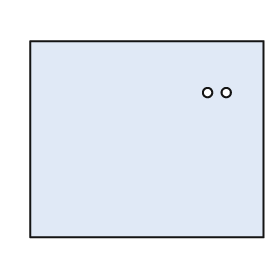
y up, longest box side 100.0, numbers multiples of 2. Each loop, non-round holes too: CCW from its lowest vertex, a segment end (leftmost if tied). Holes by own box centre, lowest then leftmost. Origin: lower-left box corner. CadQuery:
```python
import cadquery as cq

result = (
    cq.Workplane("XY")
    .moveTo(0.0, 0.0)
    .lineTo(100.0, 0.0)
    .lineTo(100.0, 84.0)
    .lineTo(0.0, 84.0)
    .close()
    .moveTo(76.0, 62.0)
    .circle(2.0)
    .moveTo(84.0, 62.0)
    .circle(2.0)
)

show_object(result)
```